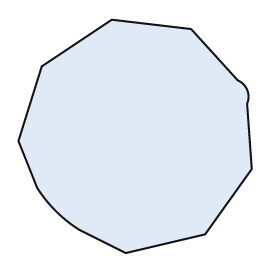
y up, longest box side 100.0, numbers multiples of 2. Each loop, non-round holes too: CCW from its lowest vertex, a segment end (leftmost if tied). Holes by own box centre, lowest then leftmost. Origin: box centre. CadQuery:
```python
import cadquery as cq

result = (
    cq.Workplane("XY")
    .moveTo(-4.0, -50.0)
    .lineTo(30.0, -42.0)
    .lineTo(50.0, -14.0)
    .lineTo(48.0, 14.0)
    .threePointArc((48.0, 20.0), (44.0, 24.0))
    .lineTo(24.0, 46.0)
    .lineTo(-10.0, 50.0)
    .lineTo(-40.0, 30.0)
    .lineTo(-50.0, -2.0)
    .lineTo(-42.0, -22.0)
    .threePointArc((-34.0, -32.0), (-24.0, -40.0))
    .close()
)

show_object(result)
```